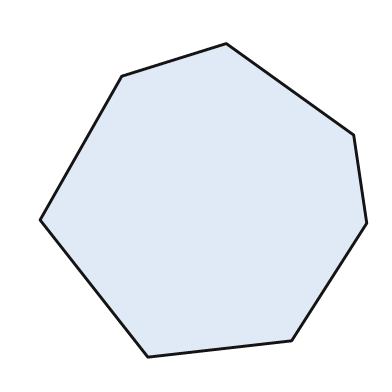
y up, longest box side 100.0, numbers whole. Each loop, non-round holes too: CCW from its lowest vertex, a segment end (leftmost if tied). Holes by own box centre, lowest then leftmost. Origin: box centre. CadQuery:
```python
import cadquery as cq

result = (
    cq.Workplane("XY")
    .moveTo(-17.0, -48.0)
    .lineTo(27.0, -43.0)
    .lineTo(50.0, -7.0)
    .lineTo(46.0, 20.0)
    .lineTo(7.0, 48.0)
    .lineTo(-25.0, 38.0)
    .lineTo(-50.0, -6.0)
    .close()
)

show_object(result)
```